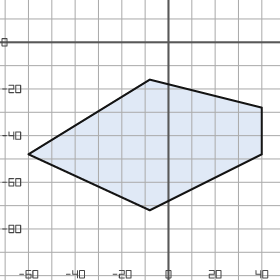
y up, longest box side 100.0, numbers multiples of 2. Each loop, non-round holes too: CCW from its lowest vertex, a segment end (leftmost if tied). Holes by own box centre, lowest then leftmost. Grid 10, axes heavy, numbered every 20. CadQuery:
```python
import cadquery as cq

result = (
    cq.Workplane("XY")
    .moveTo(-8.0, -72.0)
    .lineTo(40.0, -48.0)
    .lineTo(40.0, -28.0)
    .lineTo(-8.0, -16.0)
    .lineTo(-60.0, -48.0)
    .close()
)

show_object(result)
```